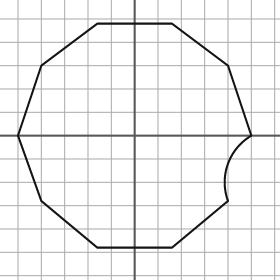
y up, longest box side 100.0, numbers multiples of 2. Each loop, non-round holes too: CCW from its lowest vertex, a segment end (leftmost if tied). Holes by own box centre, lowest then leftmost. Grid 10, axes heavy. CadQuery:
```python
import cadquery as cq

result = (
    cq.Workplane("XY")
    .moveTo(-16.0, -48.0)
    .lineTo(16.0, -48.0)
    .lineTo(40.0, -28.0)
    .threePointArc((40.0, -12.0), (50.0, 0.0))
    .lineTo(40.0, 30.0)
    .lineTo(16.0, 48.0)
    .lineTo(-16.0, 48.0)
    .lineTo(-40.0, 30.0)
    .lineTo(-50.0, 0.0)
    .lineTo(-40.0, -28.0)
    .close()
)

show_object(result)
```